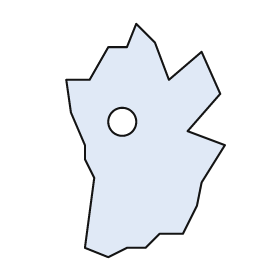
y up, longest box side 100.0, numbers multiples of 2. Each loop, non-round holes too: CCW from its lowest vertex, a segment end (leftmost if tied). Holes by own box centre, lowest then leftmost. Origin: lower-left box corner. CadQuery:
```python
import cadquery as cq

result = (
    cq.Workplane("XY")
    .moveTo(18.0, 0.0)
    .lineTo(26.0, 4.0)
    .lineTo(34.0, 4.0)
    .lineTo(40.0, 10.0)
    .lineTo(50.0, 10.0)
    .lineTo(56.0, 22.0)
    .lineTo(58.0, 32.0)
    .lineTo(68.0, 48.0)
    .lineTo(52.0, 54.0)
    .lineTo(66.0, 70.0)
    .lineTo(58.0, 88.0)
    .lineTo(44.0, 76.0)
    .lineTo(38.0, 92.0)
    .lineTo(30.0, 100.0)
    .lineTo(26.0, 90.0)
    .lineTo(18.0, 90.0)
    .lineTo(10.0, 76.0)
    .lineTo(0.0, 76.0)
    .lineTo(2.0, 62.0)
    .lineTo(8.0, 48.0)
    .lineTo(8.0, 42.0)
    .lineTo(12.0, 34.0)
    .lineTo(8.0, 4.0)
    .close()
    .moveTo(24.0, 58.0)
    .circle(6.0)
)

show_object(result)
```